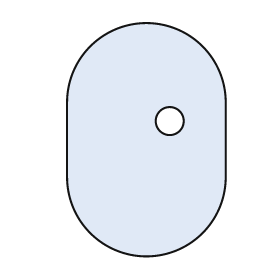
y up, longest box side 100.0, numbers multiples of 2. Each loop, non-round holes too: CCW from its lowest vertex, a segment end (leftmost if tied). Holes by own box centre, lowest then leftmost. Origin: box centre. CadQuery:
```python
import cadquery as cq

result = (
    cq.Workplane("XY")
    .moveTo(-34.0, -16.0)
    .threePointArc((0.0, -50.0), (34.0, -16.0))
    .lineTo(34.0, 16.0)
    .threePointArc((0.0, 50.0), (-34.0, 16.0))
    .close()
    .moveTo(10.0, 8.0)
    .circle(6.0)
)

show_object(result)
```